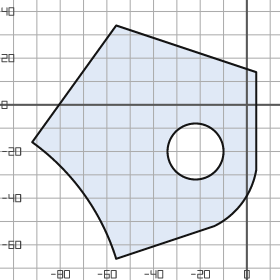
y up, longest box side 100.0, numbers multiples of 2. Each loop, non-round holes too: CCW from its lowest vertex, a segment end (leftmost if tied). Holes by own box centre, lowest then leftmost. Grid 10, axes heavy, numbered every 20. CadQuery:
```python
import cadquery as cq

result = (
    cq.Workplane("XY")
    .moveTo(-56.0, -66.0)
    .lineTo(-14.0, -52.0)
    .threePointArc((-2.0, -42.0), (4.0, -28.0))
    .lineTo(4.0, 14.0)
    .lineTo(-56.0, 34.0)
    .lineTo(-92.0, -16.0)
    .threePointArc((-70.0, -38.0), (-56.0, -66.0))
    .close()
    .moveTo(-22.0, -20.0)
    .circle(12.0)
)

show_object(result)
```